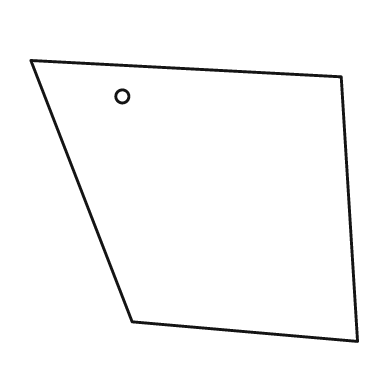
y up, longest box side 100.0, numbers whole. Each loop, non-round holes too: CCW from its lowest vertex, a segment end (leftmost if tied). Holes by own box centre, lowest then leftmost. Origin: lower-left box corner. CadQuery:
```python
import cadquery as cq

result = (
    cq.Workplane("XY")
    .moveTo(100.0, 0.0)
    .lineTo(95.0, 81.0)
    .lineTo(0.0, 86.0)
    .lineTo(31.0, 6.0)
    .close()
    .moveTo(28.0, 75.0)
    .circle(2.0)
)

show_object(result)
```